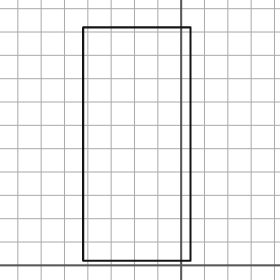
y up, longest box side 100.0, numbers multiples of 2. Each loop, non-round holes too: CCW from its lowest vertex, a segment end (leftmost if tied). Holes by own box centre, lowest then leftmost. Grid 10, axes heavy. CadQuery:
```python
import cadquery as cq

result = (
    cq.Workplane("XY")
    .moveTo(-42.0, 2.0)
    .lineTo(4.0, 2.0)
    .lineTo(4.0, 102.0)
    .lineTo(-42.0, 102.0)
    .close()
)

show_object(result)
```